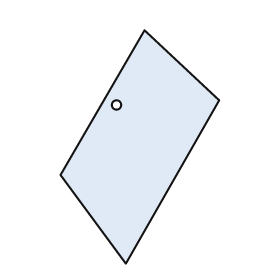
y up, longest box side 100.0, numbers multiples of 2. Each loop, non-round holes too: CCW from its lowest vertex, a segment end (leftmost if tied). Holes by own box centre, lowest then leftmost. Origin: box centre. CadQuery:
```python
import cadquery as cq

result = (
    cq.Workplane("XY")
    .moveTo(-6.0, -50.0)
    .lineTo(34.0, 20.0)
    .lineTo(2.0, 50.0)
    .lineTo(-34.0, -12.0)
    .close()
    .moveTo(-10.0, 18.0)
    .circle(2.0)
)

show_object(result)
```